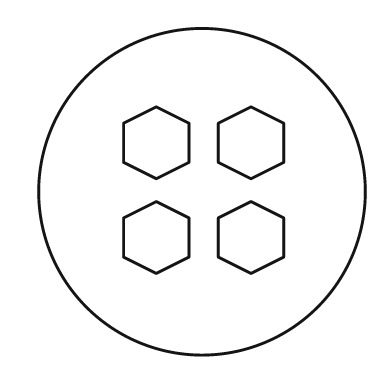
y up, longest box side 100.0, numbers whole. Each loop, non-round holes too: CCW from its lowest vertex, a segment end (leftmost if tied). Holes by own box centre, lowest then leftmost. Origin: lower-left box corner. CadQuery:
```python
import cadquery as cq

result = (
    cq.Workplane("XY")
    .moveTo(50.0, 50.0)
    .circle(50.0)
    .moveTo(36.0, 25.0)
    .lineTo(46.0, 30.0)
    .lineTo(46.0, 42.0)
    .lineTo(36.0, 47.0)
    .lineTo(26.0, 42.0)
    .lineTo(26.0, 30.0)
    .close()
    .moveTo(65.0, 25.0)
    .lineTo(75.0, 30.0)
    .lineTo(75.0, 42.0)
    .lineTo(65.0, 47.0)
    .lineTo(55.0, 42.0)
    .lineTo(55.0, 30.0)
    .close()
    .moveTo(36.0, 54.0)
    .lineTo(46.0, 59.0)
    .lineTo(46.0, 71.0)
    .lineTo(36.0, 76.0)
    .lineTo(26.0, 71.0)
    .lineTo(26.0, 59.0)
    .close()
    .moveTo(65.0, 54.0)
    .lineTo(75.0, 59.0)
    .lineTo(75.0, 71.0)
    .lineTo(65.0, 76.0)
    .lineTo(55.0, 71.0)
    .lineTo(55.0, 59.0)
    .close()
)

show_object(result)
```